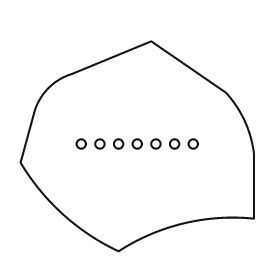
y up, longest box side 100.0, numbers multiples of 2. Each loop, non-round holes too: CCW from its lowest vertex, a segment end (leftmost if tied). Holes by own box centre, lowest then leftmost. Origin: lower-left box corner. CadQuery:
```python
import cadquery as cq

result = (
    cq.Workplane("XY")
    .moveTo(42.0, 0.0)
    .threePointArc((70.0, 12.0), (100.0, 14.0))
    .lineTo(100.0, 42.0)
    .threePointArc((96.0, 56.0), (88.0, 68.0))
    .lineTo(56.0, 90.0)
    .lineTo(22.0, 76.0)
    .threePointArc((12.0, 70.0), (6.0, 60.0))
    .lineTo(0.0, 38.0)
    .threePointArc((18.0, 16.0), (42.0, 0.0))
    .close()
    .moveTo(26.0, 46.0)
    .circle(2.0)
    .moveTo(34.0, 46.0)
    .circle(2.0)
    .moveTo(42.0, 46.0)
    .circle(2.0)
    .moveTo(50.0, 46.0)
    .circle(2.0)
    .moveTo(58.0, 46.0)
    .circle(2.0)
    .moveTo(66.0, 46.0)
    .circle(2.0)
    .moveTo(74.0, 46.0)
    .circle(2.0)
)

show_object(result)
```